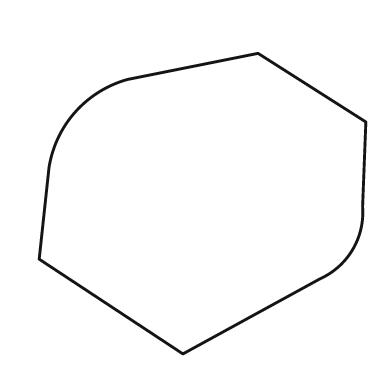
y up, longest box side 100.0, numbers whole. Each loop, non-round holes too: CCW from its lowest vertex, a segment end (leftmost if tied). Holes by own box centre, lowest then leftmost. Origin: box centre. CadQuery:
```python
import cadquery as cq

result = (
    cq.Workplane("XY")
    .moveTo(-6.0, -46.0)
    .lineTo(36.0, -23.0)
    .threePointArc((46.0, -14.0), (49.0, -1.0))
    .lineTo(50.0, 25.0)
    .lineTo(17.0, 46.0)
    .lineTo(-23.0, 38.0)
    .threePointArc((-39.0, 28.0), (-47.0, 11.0))
    .lineTo(-50.0, -17.0)
    .close()
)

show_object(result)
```